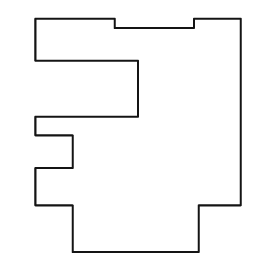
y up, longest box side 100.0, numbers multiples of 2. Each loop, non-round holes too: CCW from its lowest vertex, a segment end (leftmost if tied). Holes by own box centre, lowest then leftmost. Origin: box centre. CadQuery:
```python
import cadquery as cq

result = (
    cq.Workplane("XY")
    .moveTo(-28.0, -50.0)
    .lineTo(26.0, -50.0)
    .lineTo(26.0, -30.0)
    .lineTo(44.0, -30.0)
    .lineTo(44.0, 50.0)
    .lineTo(24.0, 50.0)
    .lineTo(24.0, 46.0)
    .lineTo(-10.0, 46.0)
    .lineTo(-10.0, 50.0)
    .lineTo(-44.0, 50.0)
    .lineTo(-44.0, 32.0)
    .lineTo(0.0, 32.0)
    .lineTo(0.0, 8.0)
    .lineTo(-44.0, 8.0)
    .lineTo(-44.0, 0.0)
    .lineTo(-28.0, 0.0)
    .lineTo(-28.0, -14.0)
    .lineTo(-44.0, -14.0)
    .lineTo(-44.0, -30.0)
    .lineTo(-28.0, -30.0)
    .close()
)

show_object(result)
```